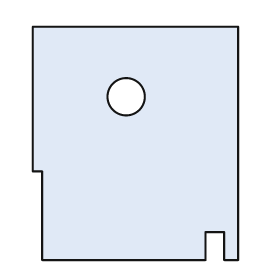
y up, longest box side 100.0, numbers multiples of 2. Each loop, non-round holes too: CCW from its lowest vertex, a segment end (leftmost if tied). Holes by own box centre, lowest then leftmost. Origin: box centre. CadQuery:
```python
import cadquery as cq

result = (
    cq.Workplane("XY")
    .moveTo(-40.0, -50.0)
    .lineTo(30.0, -50.0)
    .lineTo(30.0, -38.0)
    .lineTo(38.0, -38.0)
    .lineTo(38.0, -50.0)
    .lineTo(44.0, -50.0)
    .lineTo(44.0, 50.0)
    .lineTo(-44.0, 50.0)
    .lineTo(-44.0, -12.0)
    .lineTo(-40.0, -12.0)
    .close()
    .moveTo(-4.0, 20.0)
    .circle(8.0)
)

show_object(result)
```